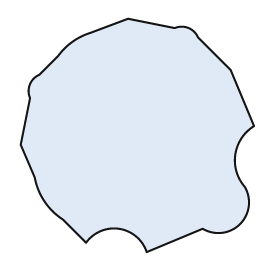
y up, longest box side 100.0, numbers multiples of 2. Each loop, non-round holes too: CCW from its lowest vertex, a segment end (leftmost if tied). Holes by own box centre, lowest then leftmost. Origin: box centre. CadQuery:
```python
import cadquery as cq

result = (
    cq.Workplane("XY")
    .moveTo(4.0, -50.0)
    .lineTo(28.0, -40.0)
    .threePointArc((44.0, -38.0), (46.0, -22.0))
    .threePointArc((42.0, -8.0), (50.0, 4.0))
    .lineTo(40.0, 28.0)
    .lineTo(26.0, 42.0)
    .threePointArc((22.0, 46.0), (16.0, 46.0))
    .lineTo(-4.0, 50.0)
    .lineTo(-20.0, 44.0)
    .threePointArc((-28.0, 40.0), (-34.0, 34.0))
    .lineTo(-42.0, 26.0)
    .threePointArc((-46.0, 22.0), (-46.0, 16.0))
    .lineTo(-50.0, -4.0)
    .lineTo(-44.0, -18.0)
    .threePointArc((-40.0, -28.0), (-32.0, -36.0))
    .lineTo(-22.0, -46.0)
    .threePointArc((-8.0, -40.0), (4.0, -50.0))
    .close()
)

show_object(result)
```